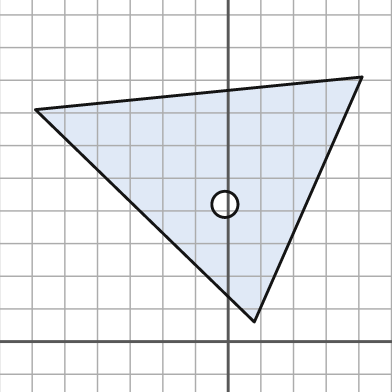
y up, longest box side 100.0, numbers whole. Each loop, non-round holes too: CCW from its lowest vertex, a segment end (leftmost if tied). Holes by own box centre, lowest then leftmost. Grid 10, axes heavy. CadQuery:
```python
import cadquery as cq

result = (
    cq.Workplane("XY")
    .moveTo(8.0, 6.0)
    .lineTo(41.0, 81.0)
    .lineTo(-59.0, 71.0)
    .close()
    .moveTo(-1.0, 42.0)
    .circle(4.0)
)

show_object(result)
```